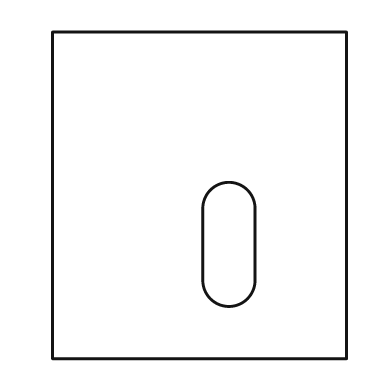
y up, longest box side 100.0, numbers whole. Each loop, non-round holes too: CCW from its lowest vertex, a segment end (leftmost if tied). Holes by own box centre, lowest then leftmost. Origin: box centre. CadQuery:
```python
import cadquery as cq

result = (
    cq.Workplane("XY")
    .moveTo(-45.0, -50.0)
    .lineTo(45.0, -50.0)
    .lineTo(45.0, 50.0)
    .lineTo(-45.0, 50.0)
    .close()
    .moveTo(1.0, -26.0)
    .threePointArc((9.0, -34.0), (17.0, -26.0))
    .lineTo(17.0, -4.0)
    .threePointArc((9.0, 4.0), (1.0, -4.0))
    .close()
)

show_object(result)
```